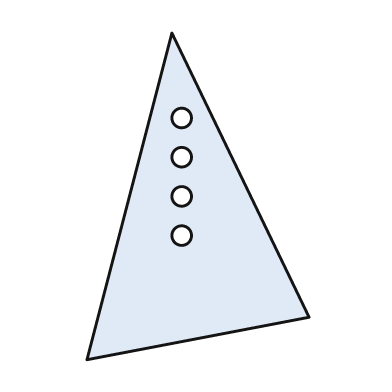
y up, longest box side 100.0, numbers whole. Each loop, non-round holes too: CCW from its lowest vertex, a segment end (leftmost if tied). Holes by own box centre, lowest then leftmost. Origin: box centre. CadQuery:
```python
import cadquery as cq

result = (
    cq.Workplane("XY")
    .moveTo(-34.0, -50.0)
    .lineTo(34.0, -37.0)
    .lineTo(-8.0, 50.0)
    .close()
    .moveTo(-5.0, -12.0)
    .circle(3.0)
    .moveTo(-5.0, 0.0)
    .circle(3.0)
    .moveTo(-5.0, 12.0)
    .circle(3.0)
    .moveTo(-5.0, 24.0)
    .circle(3.0)
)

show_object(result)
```